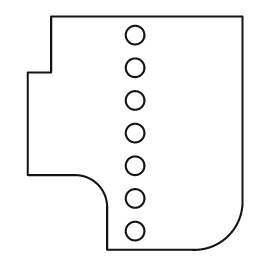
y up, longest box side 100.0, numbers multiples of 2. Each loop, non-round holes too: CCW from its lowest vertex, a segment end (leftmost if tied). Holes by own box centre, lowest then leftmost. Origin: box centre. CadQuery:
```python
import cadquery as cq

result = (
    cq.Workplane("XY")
    .moveTo(-12.0, -50.0)
    .lineTo(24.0, -50.0)
    .threePointArc((40.0, -44.0), (46.0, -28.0))
    .lineTo(46.0, 50.0)
    .lineTo(-36.0, 50.0)
    .lineTo(-36.0, 26.0)
    .lineTo(-46.0, 26.0)
    .lineTo(-46.0, -18.0)
    .lineTo(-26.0, -18.0)
    .threePointArc((-16.0, -22.0), (-12.0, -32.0))
    .close()
    .moveTo(0.0, -42.0)
    .circle(4.0)
    .moveTo(0.0, -28.0)
    .circle(4.0)
    .moveTo(0.0, -14.0)
    .circle(4.0)
    .moveTo(0.0, 0.0)
    .circle(4.0)
    .moveTo(0.0, 14.0)
    .circle(4.0)
    .moveTo(0.0, 28.0)
    .circle(4.0)
    .moveTo(0.0, 42.0)
    .circle(4.0)
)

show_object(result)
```